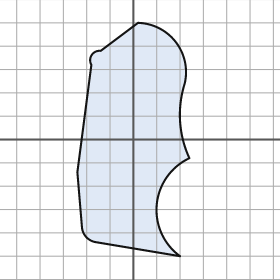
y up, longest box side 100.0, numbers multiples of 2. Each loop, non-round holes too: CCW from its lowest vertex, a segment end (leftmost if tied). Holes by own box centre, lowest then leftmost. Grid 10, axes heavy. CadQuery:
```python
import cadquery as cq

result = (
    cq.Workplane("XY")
    .moveTo(20.0, -50.0)
    .threePointArc((10.0, -28.0), (24.0, -8.0))
    .threePointArc((20.0, 8.0), (22.0, 24.0))
    .threePointArc((18.0, 42.0), (2.0, 50.0))
    .lineTo(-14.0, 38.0)
    .threePointArc((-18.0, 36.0), (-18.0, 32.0))
    .lineTo(-24.0, -14.0)
    .lineTo(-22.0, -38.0)
    .threePointArc((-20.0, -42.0), (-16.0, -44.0))
    .close()
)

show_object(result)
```